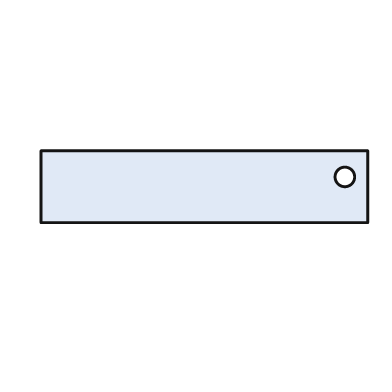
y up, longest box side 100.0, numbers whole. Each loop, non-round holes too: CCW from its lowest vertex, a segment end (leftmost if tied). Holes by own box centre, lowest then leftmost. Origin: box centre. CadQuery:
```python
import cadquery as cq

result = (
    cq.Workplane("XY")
    .moveTo(-50.0, -11.0)
    .lineTo(50.0, -11.0)
    .lineTo(50.0, 11.0)
    .lineTo(-50.0, 11.0)
    .close()
    .moveTo(43.0, 3.0)
    .circle(3.0)
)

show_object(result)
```